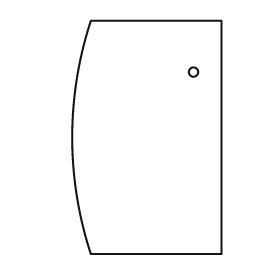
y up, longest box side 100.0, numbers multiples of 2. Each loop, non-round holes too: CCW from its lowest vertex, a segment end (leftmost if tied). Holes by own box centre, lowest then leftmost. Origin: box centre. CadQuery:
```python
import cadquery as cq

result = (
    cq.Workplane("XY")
    .moveTo(-24.0, -50.0)
    .lineTo(32.0, -50.0)
    .lineTo(32.0, 50.0)
    .lineTo(-24.0, 50.0)
    .threePointArc((-32.0, 0.0), (-24.0, -50.0))
    .close()
    .moveTo(20.0, 28.0)
    .circle(2.0)
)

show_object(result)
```